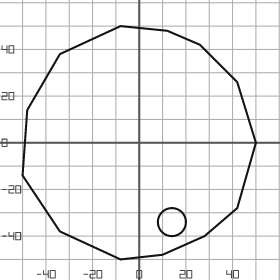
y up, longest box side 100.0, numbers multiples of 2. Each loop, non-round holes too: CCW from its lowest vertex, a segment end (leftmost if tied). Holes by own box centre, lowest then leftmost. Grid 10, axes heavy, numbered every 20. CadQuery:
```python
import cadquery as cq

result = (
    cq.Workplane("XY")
    .moveTo(-8.0, -50.0)
    .lineTo(10.0, -48.0)
    .lineTo(28.0, -40.0)
    .lineTo(42.0, -28.0)
    .lineTo(50.0, 0.0)
    .lineTo(42.0, 26.0)
    .lineTo(26.0, 42.0)
    .lineTo(12.0, 48.0)
    .lineTo(-8.0, 50.0)
    .lineTo(-34.0, 38.0)
    .lineTo(-48.0, 14.0)
    .lineTo(-50.0, -14.0)
    .lineTo(-34.0, -38.0)
    .close()
    .moveTo(14.0, -34.0)
    .circle(6.0)
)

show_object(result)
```